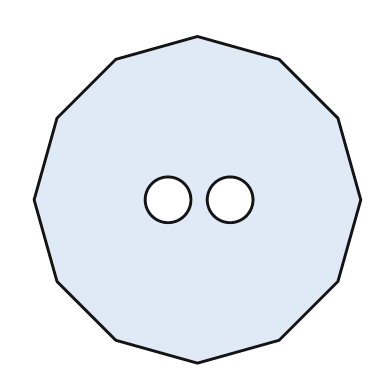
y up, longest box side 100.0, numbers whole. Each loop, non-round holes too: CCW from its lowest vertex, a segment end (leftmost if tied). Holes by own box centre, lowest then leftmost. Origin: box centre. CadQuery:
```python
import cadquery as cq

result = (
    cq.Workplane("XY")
    .moveTo(0.0, -50.0)
    .lineTo(25.0, -43.0)
    .lineTo(43.0, -25.0)
    .lineTo(50.0, 0.0)
    .lineTo(43.0, 25.0)
    .lineTo(25.0, 43.0)
    .lineTo(0.0, 50.0)
    .lineTo(-25.0, 43.0)
    .lineTo(-43.0, 25.0)
    .lineTo(-50.0, 0.0)
    .lineTo(-43.0, -25.0)
    .lineTo(-25.0, -43.0)
    .close()
    .moveTo(-9.0, 0.0)
    .circle(7.0)
    .moveTo(10.0, 0.0)
    .circle(7.0)
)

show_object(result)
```